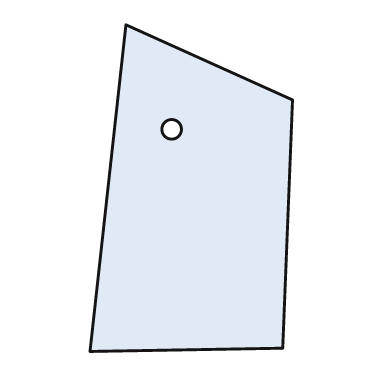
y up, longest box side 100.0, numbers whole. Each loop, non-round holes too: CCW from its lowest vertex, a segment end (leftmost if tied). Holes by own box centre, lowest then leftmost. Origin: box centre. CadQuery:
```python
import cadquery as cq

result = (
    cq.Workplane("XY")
    .moveTo(-31.0, -50.0)
    .lineTo(28.0, -49.0)
    .lineTo(31.0, 27.0)
    .lineTo(-20.0, 50.0)
    .close()
    .moveTo(-6.0, 18.0)
    .circle(3.0)
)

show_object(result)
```